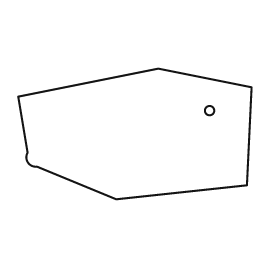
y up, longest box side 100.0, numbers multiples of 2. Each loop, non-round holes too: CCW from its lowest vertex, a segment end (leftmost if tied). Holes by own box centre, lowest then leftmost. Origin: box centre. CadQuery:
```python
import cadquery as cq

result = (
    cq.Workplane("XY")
    .moveTo(-8.0, -28.0)
    .lineTo(48.0, -22.0)
    .lineTo(50.0, 20.0)
    .lineTo(10.0, 28.0)
    .lineTo(-50.0, 16.0)
    .lineTo(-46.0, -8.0)
    .threePointArc((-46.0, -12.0), (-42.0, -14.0))
    .close()
    .moveTo(32.0, 10.0)
    .circle(2.0)
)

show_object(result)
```